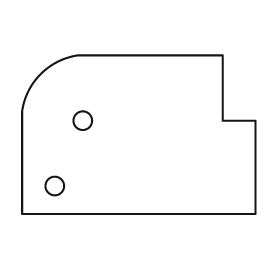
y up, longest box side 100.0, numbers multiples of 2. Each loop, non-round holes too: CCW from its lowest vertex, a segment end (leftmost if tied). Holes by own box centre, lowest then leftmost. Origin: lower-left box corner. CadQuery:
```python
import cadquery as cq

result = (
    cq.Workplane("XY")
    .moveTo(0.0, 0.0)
    .lineTo(100.0, 0.0)
    .lineTo(100.0, 40.0)
    .lineTo(86.0, 40.0)
    .lineTo(86.0, 68.0)
    .lineTo(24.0, 68.0)
    .threePointArc((8.0, 60.0), (0.0, 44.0))
    .close()
    .moveTo(14.0, 12.0)
    .circle(4.0)
    .moveTo(26.0, 40.0)
    .circle(4.0)
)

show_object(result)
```